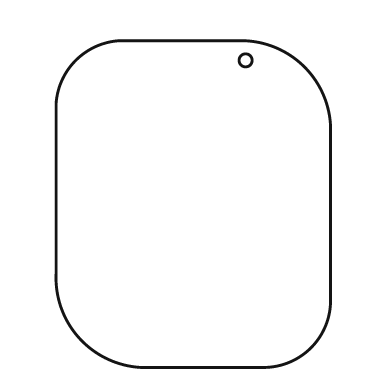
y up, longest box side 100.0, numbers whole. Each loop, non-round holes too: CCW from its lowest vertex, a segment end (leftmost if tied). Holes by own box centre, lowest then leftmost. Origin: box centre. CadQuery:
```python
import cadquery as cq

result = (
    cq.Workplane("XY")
    .moveTo(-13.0, -50.0)
    .lineTo(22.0, -50.0)
    .threePointArc((36.0, -44.0), (42.0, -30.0))
    .lineTo(42.0, 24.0)
    .threePointArc((34.0, 42.0), (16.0, 50.0))
    .lineTo(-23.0, 50.0)
    .threePointArc((-36.0, 44.0), (-42.0, 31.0))
    .lineTo(-42.0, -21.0)
    .threePointArc((-34.0, -42.0), (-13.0, -50.0))
    .close()
    .moveTo(16.0, 44.0)
    .circle(2.0)
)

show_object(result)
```